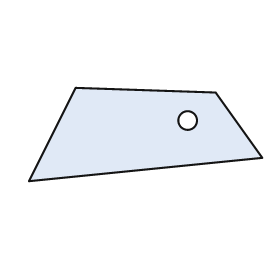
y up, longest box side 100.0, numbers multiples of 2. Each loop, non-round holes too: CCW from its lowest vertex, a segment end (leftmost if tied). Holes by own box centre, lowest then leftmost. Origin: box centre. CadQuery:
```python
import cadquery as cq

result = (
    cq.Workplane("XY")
    .moveTo(-50.0, -20.0)
    .lineTo(50.0, -10.0)
    .lineTo(30.0, 18.0)
    .lineTo(-30.0, 20.0)
    .close()
    .moveTo(18.0, 6.0)
    .circle(4.0)
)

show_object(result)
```